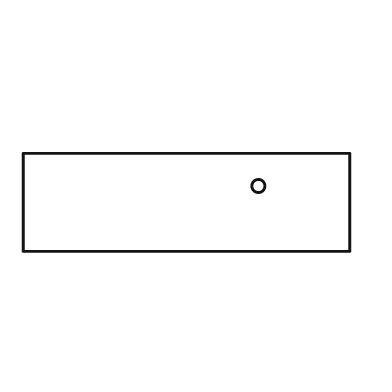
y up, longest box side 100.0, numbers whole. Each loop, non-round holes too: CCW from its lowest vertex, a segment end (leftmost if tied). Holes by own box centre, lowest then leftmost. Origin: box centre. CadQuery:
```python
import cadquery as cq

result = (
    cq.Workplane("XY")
    .moveTo(-50.0, -15.0)
    .lineTo(50.0, -15.0)
    .lineTo(50.0, 15.0)
    .lineTo(-50.0, 15.0)
    .close()
    .moveTo(22.0, 5.0)
    .circle(2.0)
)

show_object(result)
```